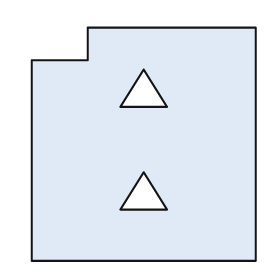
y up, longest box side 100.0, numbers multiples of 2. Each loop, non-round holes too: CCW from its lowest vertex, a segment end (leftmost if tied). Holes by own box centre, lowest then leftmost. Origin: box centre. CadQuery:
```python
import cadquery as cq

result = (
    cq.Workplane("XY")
    .moveTo(-48.0, -50.0)
    .lineTo(48.0, -50.0)
    .lineTo(48.0, 50.0)
    .lineTo(-24.0, 50.0)
    .lineTo(-24.0, 36.0)
    .lineTo(-48.0, 36.0)
    .close()
    .moveTo(-10.0, -28.0)
    .lineTo(10.0, -28.0)
    .lineTo(0.0, -12.0)
    .close()
    .moveTo(-10.0, 16.0)
    .lineTo(10.0, 16.0)
    .lineTo(0.0, 32.0)
    .close()
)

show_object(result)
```